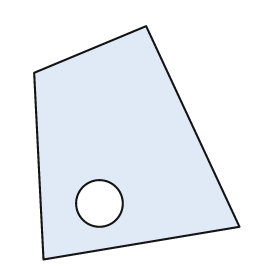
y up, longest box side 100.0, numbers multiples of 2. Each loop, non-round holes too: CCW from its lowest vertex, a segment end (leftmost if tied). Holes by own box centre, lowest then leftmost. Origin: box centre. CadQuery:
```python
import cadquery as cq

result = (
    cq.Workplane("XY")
    .moveTo(-40.0, -50.0)
    .lineTo(44.0, -36.0)
    .lineTo(4.0, 50.0)
    .lineTo(-44.0, 30.0)
    .close()
    .moveTo(-16.0, -26.0)
    .circle(10.0)
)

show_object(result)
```